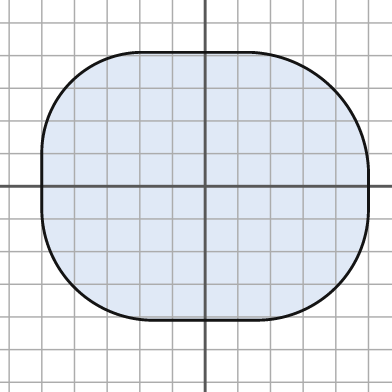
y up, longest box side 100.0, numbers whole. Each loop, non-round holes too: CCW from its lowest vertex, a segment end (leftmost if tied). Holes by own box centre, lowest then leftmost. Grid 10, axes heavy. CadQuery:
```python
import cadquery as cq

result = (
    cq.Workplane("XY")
    .moveTo(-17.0, -41.0)
    .lineTo(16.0, -41.0)
    .threePointArc((40.0, -31.0), (50.0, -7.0))
    .lineTo(50.0, 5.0)
    .threePointArc((39.0, 30.0), (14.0, 41.0))
    .lineTo(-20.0, 41.0)
    .threePointArc((-41.0, 32.0), (-50.0, 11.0))
    .lineTo(-50.0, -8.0)
    .threePointArc((-40.0, -31.0), (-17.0, -41.0))
    .close()
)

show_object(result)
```